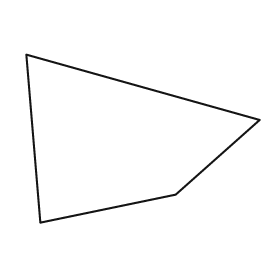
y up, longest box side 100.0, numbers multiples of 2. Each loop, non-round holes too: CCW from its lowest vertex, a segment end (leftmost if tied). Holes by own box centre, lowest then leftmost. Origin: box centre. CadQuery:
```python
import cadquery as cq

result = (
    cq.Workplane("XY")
    .moveTo(-44.0, -36.0)
    .lineTo(14.0, -24.0)
    .lineTo(50.0, 8.0)
    .lineTo(-50.0, 36.0)
    .close()
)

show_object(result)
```